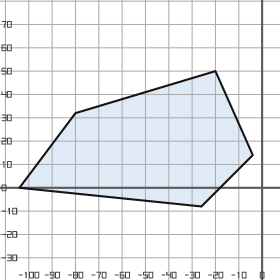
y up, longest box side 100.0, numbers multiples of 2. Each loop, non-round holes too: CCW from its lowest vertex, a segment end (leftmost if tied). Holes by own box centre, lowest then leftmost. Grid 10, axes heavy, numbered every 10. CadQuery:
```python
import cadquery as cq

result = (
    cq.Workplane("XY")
    .moveTo(-26.0, -8.0)
    .lineTo(-4.0, 14.0)
    .lineTo(-20.0, 50.0)
    .lineTo(-80.0, 32.0)
    .lineTo(-104.0, 0.0)
    .close()
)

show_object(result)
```